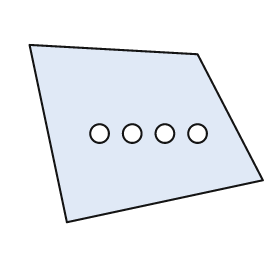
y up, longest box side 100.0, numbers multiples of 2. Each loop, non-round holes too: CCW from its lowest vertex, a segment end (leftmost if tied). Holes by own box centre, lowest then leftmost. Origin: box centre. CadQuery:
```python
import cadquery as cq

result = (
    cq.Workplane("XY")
    .moveTo(-34.0, -38.0)
    .lineTo(50.0, -20.0)
    .lineTo(22.0, 34.0)
    .lineTo(-50.0, 38.0)
    .close()
    .moveTo(-20.0, 0.0)
    .circle(4.0)
    .moveTo(-6.0, 0.0)
    .circle(4.0)
    .moveTo(8.0, 0.0)
    .circle(4.0)
    .moveTo(22.0, 0.0)
    .circle(4.0)
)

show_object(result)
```